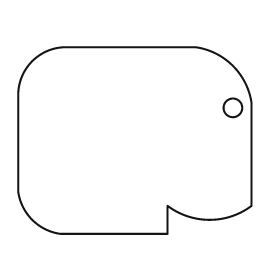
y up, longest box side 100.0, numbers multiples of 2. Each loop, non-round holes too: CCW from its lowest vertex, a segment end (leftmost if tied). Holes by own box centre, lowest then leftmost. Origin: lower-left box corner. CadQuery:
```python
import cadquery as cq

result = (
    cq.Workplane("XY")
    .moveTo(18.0, 0.0)
    .lineTo(64.0, 0.0)
    .lineTo(64.0, 12.0)
    .threePointArc((82.0, 6.0), (100.0, 12.0))
    .lineTo(100.0, 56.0)
    .threePointArc((92.0, 72.0), (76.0, 80.0))
    .lineTo(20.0, 80.0)
    .threePointArc((6.0, 74.0), (0.0, 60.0))
    .lineTo(0.0, 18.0)
    .threePointArc((6.0, 6.0), (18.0, 0.0))
    .close()
    .moveTo(92.0, 54.0)
    .circle(4.0)
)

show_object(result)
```